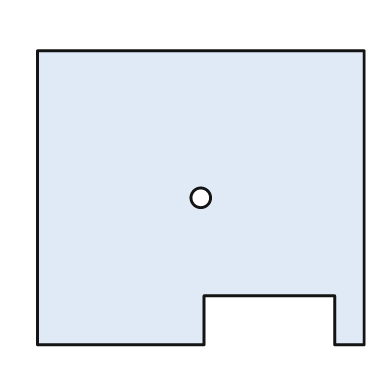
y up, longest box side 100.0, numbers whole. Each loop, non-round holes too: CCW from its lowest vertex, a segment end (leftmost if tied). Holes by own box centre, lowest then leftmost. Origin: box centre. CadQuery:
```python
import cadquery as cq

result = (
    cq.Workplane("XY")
    .moveTo(-50.0, -45.0)
    .lineTo(1.0, -45.0)
    .lineTo(1.0, -30.0)
    .lineTo(41.0, -30.0)
    .lineTo(41.0, -45.0)
    .lineTo(50.0, -45.0)
    .lineTo(50.0, 45.0)
    .lineTo(-50.0, 45.0)
    .close()
    .moveTo(0.0, 0.0)
    .circle(3.0)
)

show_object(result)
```